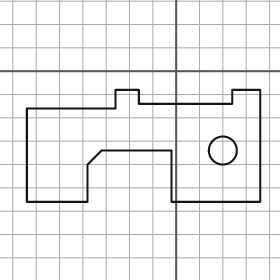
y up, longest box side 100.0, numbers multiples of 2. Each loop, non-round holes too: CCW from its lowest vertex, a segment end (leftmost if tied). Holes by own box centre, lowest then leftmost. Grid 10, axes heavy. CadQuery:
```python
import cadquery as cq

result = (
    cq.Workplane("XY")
    .moveTo(-64.0, -56.0)
    .lineTo(-38.0, -56.0)
    .lineTo(-38.0, -40.0)
    .lineTo(-32.0, -34.0)
    .lineTo(-2.0, -34.0)
    .lineTo(-2.0, -56.0)
    .lineTo(36.0, -56.0)
    .lineTo(36.0, -8.0)
    .lineTo(24.0, -8.0)
    .lineTo(24.0, -14.0)
    .lineTo(-16.0, -14.0)
    .lineTo(-16.0, -8.0)
    .lineTo(-26.0, -8.0)
    .lineTo(-26.0, -16.0)
    .lineTo(-64.0, -16.0)
    .close()
    .moveTo(20.0, -34.0)
    .circle(6.0)
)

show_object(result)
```